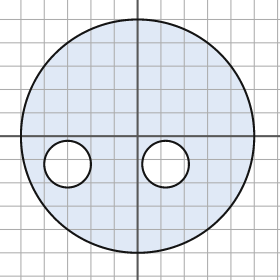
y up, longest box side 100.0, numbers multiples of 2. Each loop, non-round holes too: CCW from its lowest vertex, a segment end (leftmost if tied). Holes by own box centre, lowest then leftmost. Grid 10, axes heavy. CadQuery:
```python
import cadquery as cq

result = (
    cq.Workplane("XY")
    .moveTo(0.0, 0.0)
    .circle(50.0)
    .moveTo(-30.0, -12.0)
    .circle(10.0)
    .moveTo(12.0, -12.0)
    .circle(10.0)
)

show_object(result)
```